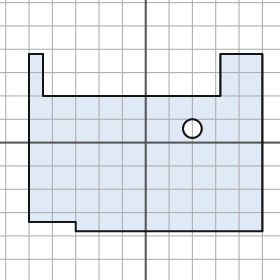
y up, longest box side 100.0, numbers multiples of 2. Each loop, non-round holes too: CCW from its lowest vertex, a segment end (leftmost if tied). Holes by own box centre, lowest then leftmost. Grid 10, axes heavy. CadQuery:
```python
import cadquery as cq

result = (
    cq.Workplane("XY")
    .moveTo(-30.0, -38.0)
    .lineTo(50.0, -38.0)
    .lineTo(50.0, 38.0)
    .lineTo(32.0, 38.0)
    .lineTo(32.0, 20.0)
    .lineTo(-44.0, 20.0)
    .lineTo(-44.0, 38.0)
    .lineTo(-50.0, 38.0)
    .lineTo(-50.0, -34.0)
    .lineTo(-30.0, -34.0)
    .close()
    .moveTo(20.0, 6.0)
    .circle(4.0)
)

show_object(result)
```